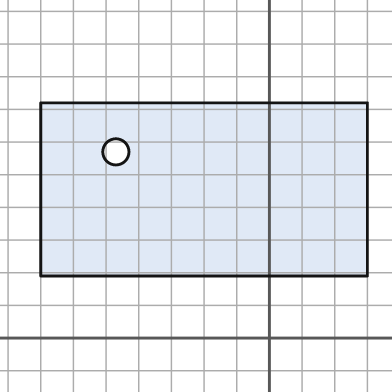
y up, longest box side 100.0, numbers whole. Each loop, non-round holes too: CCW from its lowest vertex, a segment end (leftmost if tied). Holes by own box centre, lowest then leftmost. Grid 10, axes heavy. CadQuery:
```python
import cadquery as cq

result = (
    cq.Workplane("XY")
    .moveTo(-70.0, 19.0)
    .lineTo(30.0, 19.0)
    .lineTo(30.0, 72.0)
    .lineTo(-70.0, 72.0)
    .close()
    .moveTo(-47.0, 57.0)
    .circle(4.0)
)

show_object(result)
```